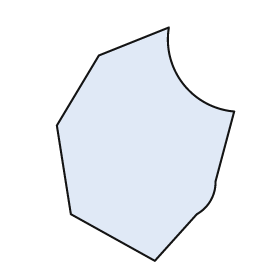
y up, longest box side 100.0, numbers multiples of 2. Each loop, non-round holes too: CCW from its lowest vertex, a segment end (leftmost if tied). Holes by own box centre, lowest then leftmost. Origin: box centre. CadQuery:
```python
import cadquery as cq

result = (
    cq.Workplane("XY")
    .moveTo(4.0, -50.0)
    .lineTo(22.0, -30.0)
    .threePointArc((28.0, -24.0), (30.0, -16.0))
    .lineTo(38.0, 14.0)
    .threePointArc((16.0, 26.0), (10.0, 50.0))
    .lineTo(-20.0, 38.0)
    .lineTo(-38.0, 8.0)
    .lineTo(-32.0, -30.0)
    .close()
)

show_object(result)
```